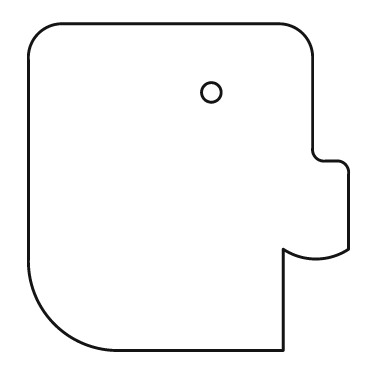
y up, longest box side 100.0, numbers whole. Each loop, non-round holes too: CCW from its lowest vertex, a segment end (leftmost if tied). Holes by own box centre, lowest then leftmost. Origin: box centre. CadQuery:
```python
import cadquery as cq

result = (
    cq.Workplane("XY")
    .moveTo(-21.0, -50.0)
    .lineTo(29.0, -50.0)
    .lineTo(29.0, -19.0)
    .threePointArc((39.0, -22.0), (49.0, -19.0))
    .lineTo(49.0, 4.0)
    .threePointArc((48.0, 7.0), (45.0, 8.0))
    .lineTo(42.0, 8.0)
    .threePointArc((39.0, 9.0), (38.0, 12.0))
    .lineTo(38.0, 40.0)
    .threePointArc((35.0, 47.0), (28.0, 50.0))
    .lineTo(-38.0, 50.0)
    .threePointArc((-46.0, 47.0), (-49.0, 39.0))
    .lineTo(-49.0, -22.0)
    .threePointArc((-41.0, -42.0), (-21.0, -50.0))
    .close()
    .moveTo(7.0, 29.0)
    .circle(3.0)
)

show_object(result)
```